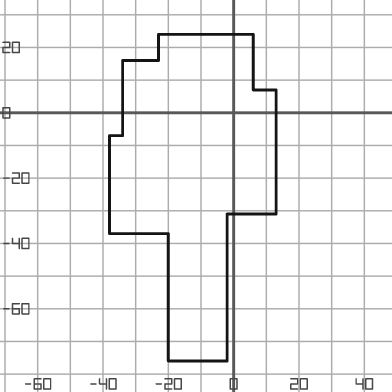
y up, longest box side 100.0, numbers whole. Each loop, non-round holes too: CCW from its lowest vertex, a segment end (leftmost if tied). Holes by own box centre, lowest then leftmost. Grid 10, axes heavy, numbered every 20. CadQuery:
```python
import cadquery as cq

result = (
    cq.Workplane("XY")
    .moveTo(-20.0, -76.0)
    .lineTo(-2.0, -76.0)
    .lineTo(-2.0, -31.0)
    .lineTo(13.0, -31.0)
    .lineTo(13.0, 7.0)
    .lineTo(6.0, 7.0)
    .lineTo(6.0, 24.0)
    .lineTo(-23.0, 24.0)
    .lineTo(-23.0, 16.0)
    .lineTo(-34.0, 16.0)
    .lineTo(-34.0, -7.0)
    .lineTo(-38.0, -7.0)
    .lineTo(-38.0, -37.0)
    .lineTo(-20.0, -37.0)
    .close()
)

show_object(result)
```